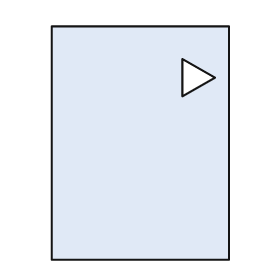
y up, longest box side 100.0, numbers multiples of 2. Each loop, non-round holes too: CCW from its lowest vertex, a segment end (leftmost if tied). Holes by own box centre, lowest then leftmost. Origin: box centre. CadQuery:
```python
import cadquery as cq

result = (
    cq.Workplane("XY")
    .moveTo(-38.0, -50.0)
    .lineTo(38.0, -50.0)
    .lineTo(38.0, 50.0)
    .lineTo(-38.0, 50.0)
    .close()
    .moveTo(18.0, 20.0)
    .lineTo(32.0, 28.0)
    .lineTo(18.0, 36.0)
    .close()
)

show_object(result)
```